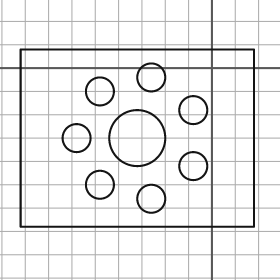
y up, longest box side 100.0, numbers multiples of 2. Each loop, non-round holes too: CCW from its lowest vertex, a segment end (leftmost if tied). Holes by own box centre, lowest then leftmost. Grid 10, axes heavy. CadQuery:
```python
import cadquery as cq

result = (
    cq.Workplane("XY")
    .moveTo(-82.0, -68.0)
    .lineTo(18.0, -68.0)
    .lineTo(18.0, 8.0)
    .lineTo(-82.0, 8.0)
    .close()
    .moveTo(-26.0, -56.0)
    .circle(6.0)
    .moveTo(-48.0, -50.0)
    .circle(6.0)
    .moveTo(-8.0, -42.0)
    .circle(6.0)
    .moveTo(-58.0, -30.0)
    .circle(6.0)
    .moveTo(-32.0, -30.0)
    .circle(12.0)
    .moveTo(-8.0, -18.0)
    .circle(6.0)
    .moveTo(-48.0, -10.0)
    .circle(6.0)
    .moveTo(-26.0, -4.0)
    .circle(6.0)
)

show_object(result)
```